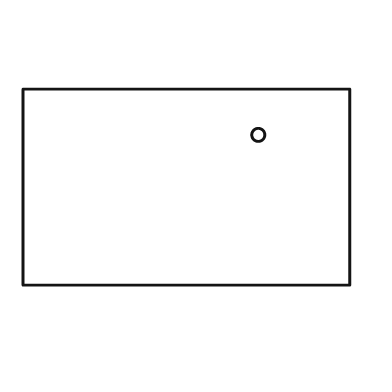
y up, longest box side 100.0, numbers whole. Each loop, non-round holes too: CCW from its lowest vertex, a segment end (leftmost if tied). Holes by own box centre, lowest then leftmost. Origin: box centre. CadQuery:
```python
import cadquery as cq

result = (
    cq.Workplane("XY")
    .moveTo(-50.0, -30.0)
    .lineTo(50.0, -30.0)
    .lineTo(50.0, 30.0)
    .lineTo(-50.0, 30.0)
    .close()
    .moveTo(22.0, 16.0)
    .circle(2.0)
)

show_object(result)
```